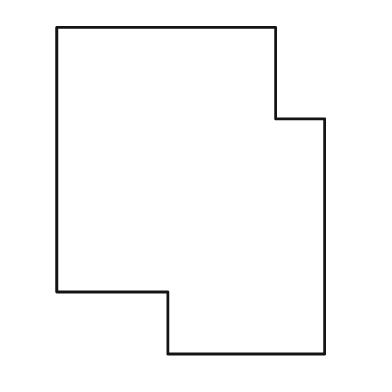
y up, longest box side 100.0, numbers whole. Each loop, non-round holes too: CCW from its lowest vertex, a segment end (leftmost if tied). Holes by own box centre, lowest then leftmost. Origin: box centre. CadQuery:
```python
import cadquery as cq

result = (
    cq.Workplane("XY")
    .moveTo(-7.0, -50.0)
    .lineTo(41.0, -50.0)
    .lineTo(41.0, 22.0)
    .lineTo(26.0, 22.0)
    .lineTo(26.0, 50.0)
    .lineTo(-41.0, 50.0)
    .lineTo(-41.0, -31.0)
    .lineTo(-7.0, -31.0)
    .close()
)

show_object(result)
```